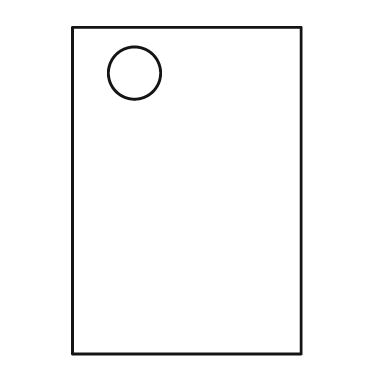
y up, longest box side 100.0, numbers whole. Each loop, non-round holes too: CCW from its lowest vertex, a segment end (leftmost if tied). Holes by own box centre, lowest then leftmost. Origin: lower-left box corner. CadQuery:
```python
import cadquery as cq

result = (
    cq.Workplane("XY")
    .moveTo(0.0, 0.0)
    .lineTo(70.0, 0.0)
    .lineTo(70.0, 100.0)
    .lineTo(0.0, 100.0)
    .close()
    .moveTo(19.0, 86.0)
    .circle(8.0)
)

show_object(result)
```